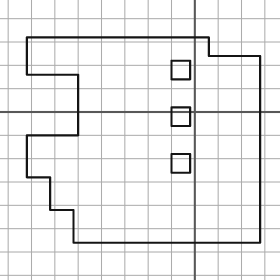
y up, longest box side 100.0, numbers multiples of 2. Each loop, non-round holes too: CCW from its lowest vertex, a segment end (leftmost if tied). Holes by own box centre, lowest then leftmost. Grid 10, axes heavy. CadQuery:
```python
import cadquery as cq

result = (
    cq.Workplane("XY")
    .moveTo(-52.0, -56.0)
    .lineTo(28.0, -56.0)
    .lineTo(28.0, 24.0)
    .lineTo(6.0, 24.0)
    .lineTo(6.0, 32.0)
    .lineTo(-72.0, 32.0)
    .lineTo(-72.0, 16.0)
    .lineTo(-50.0, 16.0)
    .lineTo(-50.0, -10.0)
    .lineTo(-72.0, -10.0)
    .lineTo(-72.0, -28.0)
    .lineTo(-62.0, -28.0)
    .lineTo(-62.0, -42.0)
    .lineTo(-52.0, -42.0)
    .close()
    .moveTo(-10.0, -26.0)
    .lineTo(-2.0, -26.0)
    .lineTo(-2.0, -18.0)
    .lineTo(-10.0, -18.0)
    .close()
    .moveTo(-10.0, -6.0)
    .lineTo(-2.0, -6.0)
    .lineTo(-2.0, 2.0)
    .lineTo(-10.0, 2.0)
    .close()
    .moveTo(-10.0, 14.0)
    .lineTo(-2.0, 14.0)
    .lineTo(-2.0, 22.0)
    .lineTo(-10.0, 22.0)
    .close()
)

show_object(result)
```